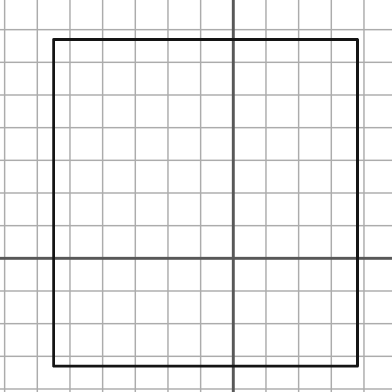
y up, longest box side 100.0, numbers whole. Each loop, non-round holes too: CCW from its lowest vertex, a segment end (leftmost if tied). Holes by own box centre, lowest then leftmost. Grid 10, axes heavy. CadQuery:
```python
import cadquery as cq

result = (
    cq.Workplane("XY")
    .moveTo(-55.0, -33.0)
    .lineTo(38.0, -33.0)
    .lineTo(38.0, 67.0)
    .lineTo(-55.0, 67.0)
    .close()
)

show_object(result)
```